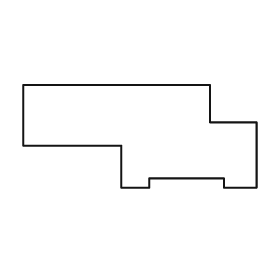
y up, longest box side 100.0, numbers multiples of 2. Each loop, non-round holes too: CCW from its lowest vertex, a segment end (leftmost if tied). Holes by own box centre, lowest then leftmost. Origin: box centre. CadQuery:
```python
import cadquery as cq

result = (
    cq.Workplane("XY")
    .moveTo(-8.0, -22.0)
    .lineTo(4.0, -22.0)
    .lineTo(4.0, -18.0)
    .lineTo(36.0, -18.0)
    .lineTo(36.0, -22.0)
    .lineTo(50.0, -22.0)
    .lineTo(50.0, 6.0)
    .lineTo(30.0, 6.0)
    .lineTo(30.0, 22.0)
    .lineTo(-50.0, 22.0)
    .lineTo(-50.0, -4.0)
    .lineTo(-8.0, -4.0)
    .close()
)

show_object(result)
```